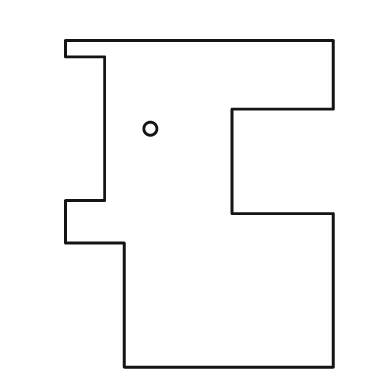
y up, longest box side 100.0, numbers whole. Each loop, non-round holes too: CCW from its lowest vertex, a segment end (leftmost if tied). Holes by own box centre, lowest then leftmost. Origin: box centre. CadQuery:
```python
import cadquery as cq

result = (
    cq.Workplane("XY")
    .moveTo(-23.0, -50.0)
    .lineTo(41.0, -50.0)
    .lineTo(41.0, -3.0)
    .lineTo(10.0, -3.0)
    .lineTo(10.0, 29.0)
    .lineTo(41.0, 29.0)
    .lineTo(41.0, 50.0)
    .lineTo(-41.0, 50.0)
    .lineTo(-41.0, 45.0)
    .lineTo(-29.0, 45.0)
    .lineTo(-29.0, 1.0)
    .lineTo(-41.0, 1.0)
    .lineTo(-41.0, -12.0)
    .lineTo(-23.0, -12.0)
    .close()
    .moveTo(-15.0, 23.0)
    .circle(2.0)
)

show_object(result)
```